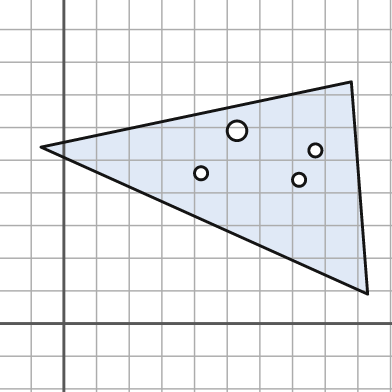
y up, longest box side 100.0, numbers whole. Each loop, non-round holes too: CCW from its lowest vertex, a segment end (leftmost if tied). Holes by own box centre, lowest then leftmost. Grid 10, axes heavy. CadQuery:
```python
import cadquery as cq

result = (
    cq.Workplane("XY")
    .moveTo(93.0, 9.0)
    .lineTo(88.0, 74.0)
    .lineTo(-7.0, 54.0)
    .close()
    .moveTo(72.0, 44.0)
    .circle(2.0)
    .moveTo(42.0, 46.0)
    .circle(2.0)
    .moveTo(77.0, 53.0)
    .circle(2.0)
    .moveTo(53.0, 59.0)
    .circle(3.0)
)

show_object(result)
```